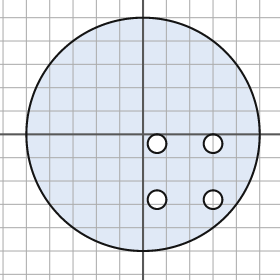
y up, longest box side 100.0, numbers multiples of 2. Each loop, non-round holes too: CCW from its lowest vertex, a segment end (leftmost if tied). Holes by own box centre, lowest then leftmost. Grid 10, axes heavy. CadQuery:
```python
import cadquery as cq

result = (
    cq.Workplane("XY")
    .moveTo(0.0, 0.0)
    .circle(50.0)
    .moveTo(6.0, -28.0)
    .circle(4.0)
    .moveTo(30.0, -28.0)
    .circle(4.0)
    .moveTo(6.0, -4.0)
    .circle(4.0)
    .moveTo(30.0, -4.0)
    .circle(4.0)
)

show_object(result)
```